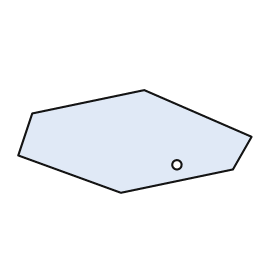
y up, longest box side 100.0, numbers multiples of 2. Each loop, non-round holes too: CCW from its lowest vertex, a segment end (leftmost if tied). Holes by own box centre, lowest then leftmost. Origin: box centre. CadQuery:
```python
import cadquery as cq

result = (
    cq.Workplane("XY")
    .moveTo(-6.0, -22.0)
    .lineTo(42.0, -12.0)
    .lineTo(50.0, 2.0)
    .lineTo(4.0, 22.0)
    .lineTo(-44.0, 12.0)
    .lineTo(-50.0, -6.0)
    .close()
    .moveTo(18.0, -10.0)
    .circle(2.0)
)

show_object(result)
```